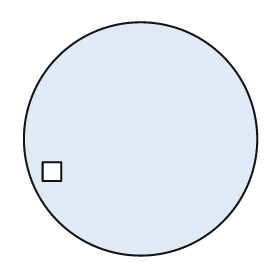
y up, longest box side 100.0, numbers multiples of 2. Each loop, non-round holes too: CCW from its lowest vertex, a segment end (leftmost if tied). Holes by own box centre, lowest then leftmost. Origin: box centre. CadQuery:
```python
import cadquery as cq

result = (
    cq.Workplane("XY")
    .moveTo(0.0, 0.0)
    .circle(50.0)
    .moveTo(-42.0, -18.0)
    .lineTo(-34.0, -18.0)
    .lineTo(-34.0, -10.0)
    .lineTo(-42.0, -10.0)
    .close()
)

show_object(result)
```